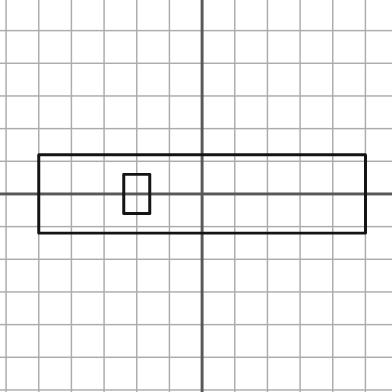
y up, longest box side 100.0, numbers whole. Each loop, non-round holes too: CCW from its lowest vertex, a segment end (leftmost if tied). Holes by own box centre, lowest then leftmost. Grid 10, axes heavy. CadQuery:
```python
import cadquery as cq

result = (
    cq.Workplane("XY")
    .moveTo(-50.0, -12.0)
    .lineTo(50.0, -12.0)
    .lineTo(50.0, 12.0)
    .lineTo(-50.0, 12.0)
    .close()
    .moveTo(-24.0, -6.0)
    .lineTo(-16.0, -6.0)
    .lineTo(-16.0, 6.0)
    .lineTo(-24.0, 6.0)
    .close()
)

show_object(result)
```